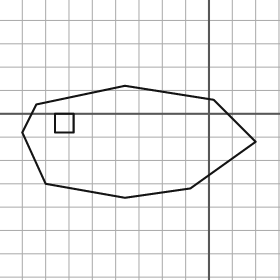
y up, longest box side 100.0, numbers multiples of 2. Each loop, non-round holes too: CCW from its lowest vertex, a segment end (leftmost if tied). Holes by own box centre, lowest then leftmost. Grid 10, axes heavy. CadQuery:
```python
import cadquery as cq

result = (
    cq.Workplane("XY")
    .moveTo(-36.0, -36.0)
    .lineTo(-8.0, -32.0)
    .lineTo(20.0, -12.0)
    .lineTo(2.0, 6.0)
    .lineTo(-36.0, 12.0)
    .lineTo(-74.0, 4.0)
    .lineTo(-80.0, -8.0)
    .lineTo(-70.0, -30.0)
    .close()
    .moveTo(-66.0, -8.0)
    .lineTo(-58.0, -8.0)
    .lineTo(-58.0, 0.0)
    .lineTo(-66.0, 0.0)
    .close()
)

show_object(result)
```